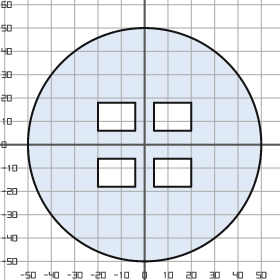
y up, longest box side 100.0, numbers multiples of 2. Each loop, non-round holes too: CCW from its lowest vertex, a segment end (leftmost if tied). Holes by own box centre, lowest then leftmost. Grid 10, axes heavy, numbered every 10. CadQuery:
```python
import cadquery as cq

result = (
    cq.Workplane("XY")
    .moveTo(0.0, 0.0)
    .circle(50.0)
    .moveTo(-20.0, -18.0)
    .lineTo(-4.0, -18.0)
    .lineTo(-4.0, -6.0)
    .lineTo(-20.0, -6.0)
    .close()
    .moveTo(4.0, -18.0)
    .lineTo(20.0, -18.0)
    .lineTo(20.0, -6.0)
    .lineTo(4.0, -6.0)
    .close()
    .moveTo(-20.0, 6.0)
    .lineTo(-4.0, 6.0)
    .lineTo(-4.0, 18.0)
    .lineTo(-20.0, 18.0)
    .close()
    .moveTo(4.0, 6.0)
    .lineTo(20.0, 6.0)
    .lineTo(20.0, 18.0)
    .lineTo(4.0, 18.0)
    .close()
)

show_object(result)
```